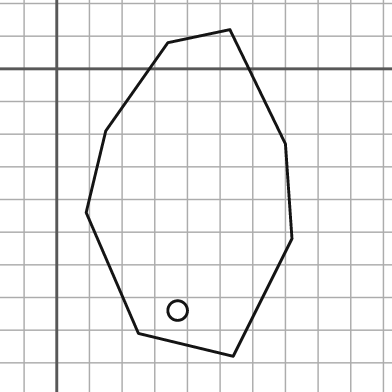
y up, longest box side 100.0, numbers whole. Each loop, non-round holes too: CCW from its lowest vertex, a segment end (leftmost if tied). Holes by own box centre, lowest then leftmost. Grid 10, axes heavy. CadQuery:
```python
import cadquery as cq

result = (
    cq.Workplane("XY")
    .moveTo(54.0, -88.0)
    .lineTo(72.0, -52.0)
    .lineTo(70.0, -23.0)
    .lineTo(53.0, 12.0)
    .lineTo(34.0, 8.0)
    .lineTo(15.0, -19.0)
    .lineTo(9.0, -44.0)
    .lineTo(25.0, -81.0)
    .close()
    .moveTo(37.0, -74.0)
    .circle(3.0)
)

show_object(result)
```